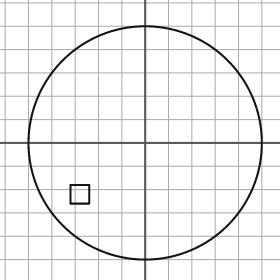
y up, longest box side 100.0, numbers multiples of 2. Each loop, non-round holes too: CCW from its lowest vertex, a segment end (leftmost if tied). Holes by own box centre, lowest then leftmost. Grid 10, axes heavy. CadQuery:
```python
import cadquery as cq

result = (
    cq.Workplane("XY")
    .moveTo(0.0, 0.0)
    .circle(50.0)
    .moveTo(-32.0, -26.0)
    .lineTo(-24.0, -26.0)
    .lineTo(-24.0, -18.0)
    .lineTo(-32.0, -18.0)
    .close()
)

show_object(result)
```